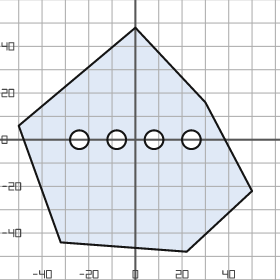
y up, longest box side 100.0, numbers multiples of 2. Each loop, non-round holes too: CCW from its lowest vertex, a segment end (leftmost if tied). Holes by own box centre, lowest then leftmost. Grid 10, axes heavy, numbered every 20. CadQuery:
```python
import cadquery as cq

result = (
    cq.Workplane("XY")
    .moveTo(22.0, -48.0)
    .lineTo(50.0, -22.0)
    .lineTo(30.0, 16.0)
    .lineTo(0.0, 48.0)
    .lineTo(-50.0, 6.0)
    .lineTo(-32.0, -44.0)
    .close()
    .moveTo(-24.0, 0.0)
    .circle(4.0)
    .moveTo(-8.0, 0.0)
    .circle(4.0)
    .moveTo(8.0, 0.0)
    .circle(4.0)
    .moveTo(24.0, 0.0)
    .circle(4.0)
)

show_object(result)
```